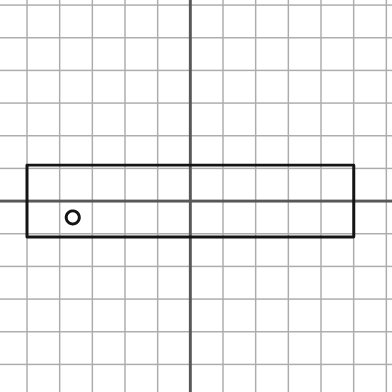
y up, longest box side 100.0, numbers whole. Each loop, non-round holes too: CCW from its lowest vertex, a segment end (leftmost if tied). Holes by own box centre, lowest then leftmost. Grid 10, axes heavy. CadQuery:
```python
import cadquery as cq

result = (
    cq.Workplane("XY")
    .moveTo(-50.0, -11.0)
    .lineTo(50.0, -11.0)
    .lineTo(50.0, 11.0)
    .lineTo(-50.0, 11.0)
    .close()
    .moveTo(-36.0, -5.0)
    .circle(2.0)
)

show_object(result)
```